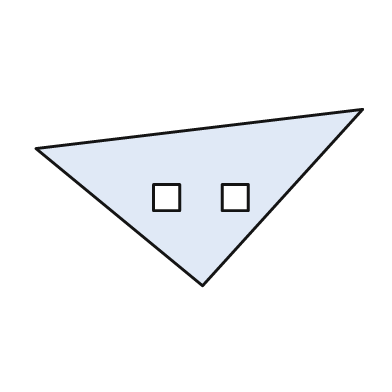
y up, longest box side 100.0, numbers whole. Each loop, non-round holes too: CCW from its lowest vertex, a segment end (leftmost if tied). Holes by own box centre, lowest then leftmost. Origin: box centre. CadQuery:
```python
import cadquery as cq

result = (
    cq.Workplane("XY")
    .moveTo(1.0, -27.0)
    .lineTo(50.0, 27.0)
    .lineTo(-50.0, 15.0)
    .close()
    .moveTo(-14.0, -4.0)
    .lineTo(-6.0, -4.0)
    .lineTo(-6.0, 4.0)
    .lineTo(-14.0, 4.0)
    .close()
    .moveTo(7.0, -4.0)
    .lineTo(15.0, -4.0)
    .lineTo(15.0, 4.0)
    .lineTo(7.0, 4.0)
    .close()
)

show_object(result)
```